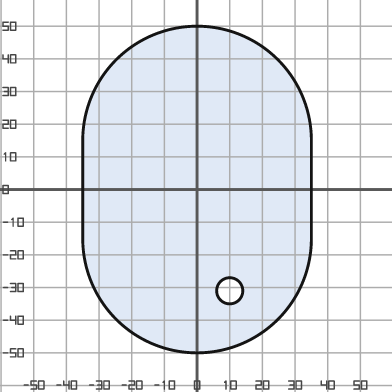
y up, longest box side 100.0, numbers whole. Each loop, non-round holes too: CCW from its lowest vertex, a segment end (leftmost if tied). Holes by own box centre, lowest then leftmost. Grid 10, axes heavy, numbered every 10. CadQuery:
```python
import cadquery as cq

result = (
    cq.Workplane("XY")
    .moveTo(-35.0, -15.0)
    .threePointArc((0.0, -50.0), (35.0, -15.0))
    .lineTo(35.0, 15.0)
    .threePointArc((0.0, 50.0), (-35.0, 15.0))
    .close()
    .moveTo(10.0, -31.0)
    .circle(4.0)
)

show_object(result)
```